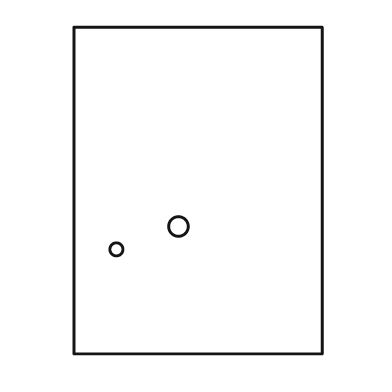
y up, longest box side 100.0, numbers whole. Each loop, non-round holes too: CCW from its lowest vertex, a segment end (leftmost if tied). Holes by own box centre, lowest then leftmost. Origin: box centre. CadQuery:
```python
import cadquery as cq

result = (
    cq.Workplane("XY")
    .moveTo(-38.0, -50.0)
    .lineTo(38.0, -50.0)
    .lineTo(38.0, 50.0)
    .lineTo(-38.0, 50.0)
    .close()
    .moveTo(-25.0, -18.0)
    .circle(2.0)
    .moveTo(-6.0, -11.0)
    .circle(3.0)
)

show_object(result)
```